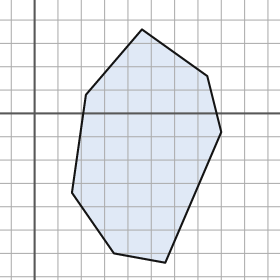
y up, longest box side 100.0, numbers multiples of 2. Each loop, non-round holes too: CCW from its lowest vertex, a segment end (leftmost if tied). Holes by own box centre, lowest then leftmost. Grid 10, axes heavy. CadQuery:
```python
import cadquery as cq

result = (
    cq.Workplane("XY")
    .moveTo(56.0, -64.0)
    .lineTo(80.0, -8.0)
    .lineTo(74.0, 16.0)
    .lineTo(46.0, 36.0)
    .lineTo(22.0, 8.0)
    .lineTo(16.0, -34.0)
    .lineTo(34.0, -60.0)
    .close()
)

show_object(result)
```